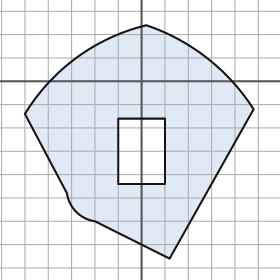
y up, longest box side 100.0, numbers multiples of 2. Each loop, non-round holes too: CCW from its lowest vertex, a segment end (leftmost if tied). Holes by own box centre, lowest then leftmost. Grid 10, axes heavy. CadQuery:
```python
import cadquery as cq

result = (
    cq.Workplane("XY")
    .moveTo(12.0, -76.0)
    .lineTo(48.0, -12.0)
    .threePointArc((28.0, 10.0), (2.0, 24.0))
    .threePointArc((-28.0, 10.0), (-50.0, -14.0))
    .lineTo(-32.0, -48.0)
    .threePointArc((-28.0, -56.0), (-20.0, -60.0))
    .close()
    .moveTo(-10.0, -44.0)
    .lineTo(10.0, -44.0)
    .lineTo(10.0, -16.0)
    .lineTo(-10.0, -16.0)
    .close()
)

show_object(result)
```